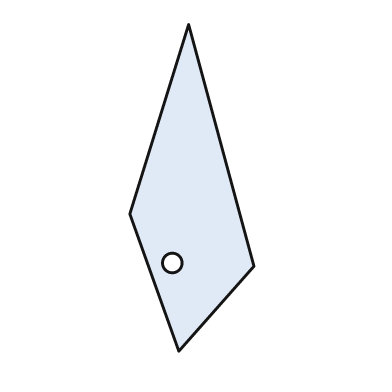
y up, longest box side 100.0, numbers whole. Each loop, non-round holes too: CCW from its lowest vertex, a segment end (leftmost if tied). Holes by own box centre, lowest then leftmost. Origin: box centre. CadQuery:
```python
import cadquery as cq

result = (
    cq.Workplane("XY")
    .moveTo(-4.0, -50.0)
    .lineTo(19.0, -24.0)
    .lineTo(-1.0, 50.0)
    .lineTo(-19.0, -8.0)
    .close()
    .moveTo(-6.0, -23.0)
    .circle(3.0)
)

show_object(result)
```